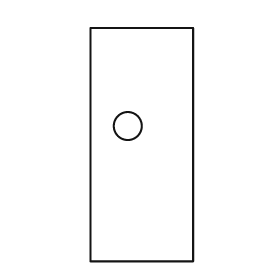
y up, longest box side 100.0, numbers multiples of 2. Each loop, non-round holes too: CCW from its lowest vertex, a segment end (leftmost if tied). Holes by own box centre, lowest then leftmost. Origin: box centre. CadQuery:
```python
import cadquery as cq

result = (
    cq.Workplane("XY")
    .moveTo(-22.0, -50.0)
    .lineTo(22.0, -50.0)
    .lineTo(22.0, 50.0)
    .lineTo(-22.0, 50.0)
    .close()
    .moveTo(-6.0, 8.0)
    .circle(6.0)
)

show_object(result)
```